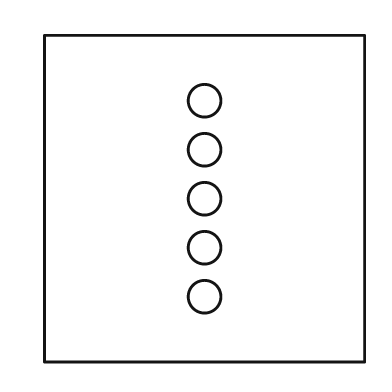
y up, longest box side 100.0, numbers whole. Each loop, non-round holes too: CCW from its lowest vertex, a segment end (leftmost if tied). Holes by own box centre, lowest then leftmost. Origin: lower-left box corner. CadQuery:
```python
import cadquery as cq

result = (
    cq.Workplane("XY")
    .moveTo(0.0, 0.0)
    .lineTo(98.0, 0.0)
    .lineTo(98.0, 100.0)
    .lineTo(0.0, 100.0)
    .close()
    .moveTo(49.0, 20.0)
    .circle(5.0)
    .moveTo(49.0, 35.0)
    .circle(5.0)
    .moveTo(49.0, 50.0)
    .circle(5.0)
    .moveTo(49.0, 65.0)
    .circle(5.0)
    .moveTo(49.0, 80.0)
    .circle(5.0)
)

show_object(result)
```